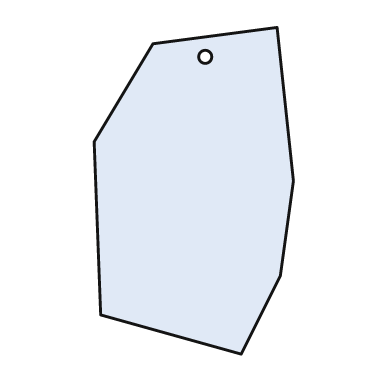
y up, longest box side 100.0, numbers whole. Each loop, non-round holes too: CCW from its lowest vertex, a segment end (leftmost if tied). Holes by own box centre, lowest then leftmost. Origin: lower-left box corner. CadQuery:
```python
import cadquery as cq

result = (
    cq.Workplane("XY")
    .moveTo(45.0, 0.0)
    .lineTo(57.0, 24.0)
    .lineTo(61.0, 53.0)
    .lineTo(56.0, 100.0)
    .lineTo(18.0, 95.0)
    .lineTo(0.0, 65.0)
    .lineTo(2.0, 12.0)
    .close()
    .moveTo(34.0, 91.0)
    .circle(2.0)
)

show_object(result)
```